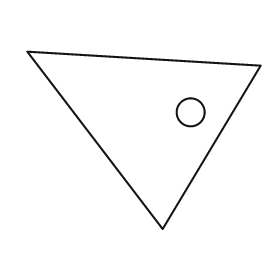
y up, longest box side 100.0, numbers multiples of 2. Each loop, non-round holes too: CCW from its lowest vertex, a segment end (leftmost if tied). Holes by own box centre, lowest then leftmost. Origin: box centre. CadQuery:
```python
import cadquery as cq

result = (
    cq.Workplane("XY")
    .moveTo(8.0, -38.0)
    .lineTo(50.0, 32.0)
    .lineTo(-50.0, 38.0)
    .close()
    .moveTo(20.0, 12.0)
    .circle(6.0)
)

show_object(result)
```